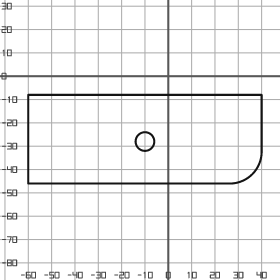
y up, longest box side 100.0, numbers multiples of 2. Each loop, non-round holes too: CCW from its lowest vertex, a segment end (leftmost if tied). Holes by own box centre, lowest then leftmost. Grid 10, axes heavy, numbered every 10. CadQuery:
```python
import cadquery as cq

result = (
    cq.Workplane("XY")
    .moveTo(-60.0, -46.0)
    .lineTo(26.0, -46.0)
    .threePointArc((36.0, -42.0), (40.0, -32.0))
    .lineTo(40.0, -8.0)
    .lineTo(-60.0, -8.0)
    .close()
    .moveTo(-10.0, -28.0)
    .circle(4.0)
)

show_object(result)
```